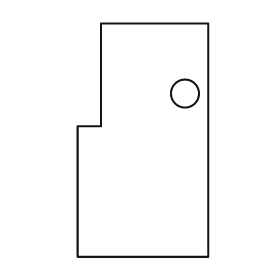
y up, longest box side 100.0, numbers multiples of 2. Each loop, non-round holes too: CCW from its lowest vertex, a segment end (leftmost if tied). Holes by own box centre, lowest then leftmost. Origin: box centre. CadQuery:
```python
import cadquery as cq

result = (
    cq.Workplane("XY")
    .moveTo(-28.0, -50.0)
    .lineTo(28.0, -50.0)
    .lineTo(28.0, 50.0)
    .lineTo(-18.0, 50.0)
    .lineTo(-18.0, 6.0)
    .lineTo(-28.0, 6.0)
    .close()
    .moveTo(18.0, 20.0)
    .circle(6.0)
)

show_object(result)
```